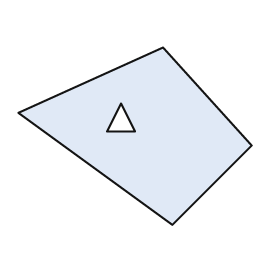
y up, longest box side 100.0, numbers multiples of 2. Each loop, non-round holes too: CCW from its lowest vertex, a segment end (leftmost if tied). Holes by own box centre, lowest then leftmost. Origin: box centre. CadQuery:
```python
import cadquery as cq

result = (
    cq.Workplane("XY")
    .moveTo(16.0, -38.0)
    .lineTo(50.0, -4.0)
    .lineTo(12.0, 38.0)
    .lineTo(-50.0, 10.0)
    .close()
    .moveTo(-12.0, 2.0)
    .lineTo(0.0, 2.0)
    .lineTo(-6.0, 14.0)
    .close()
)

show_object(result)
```